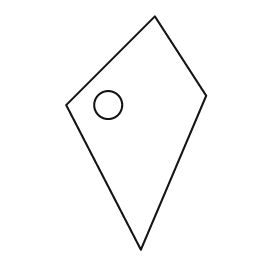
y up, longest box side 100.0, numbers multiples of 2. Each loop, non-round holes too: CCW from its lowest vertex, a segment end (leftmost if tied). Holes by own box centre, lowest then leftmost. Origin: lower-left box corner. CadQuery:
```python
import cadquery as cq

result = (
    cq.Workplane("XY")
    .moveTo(32.0, 0.0)
    .lineTo(60.0, 66.0)
    .lineTo(38.0, 100.0)
    .lineTo(0.0, 62.0)
    .close()
    .moveTo(18.0, 62.0)
    .circle(6.0)
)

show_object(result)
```